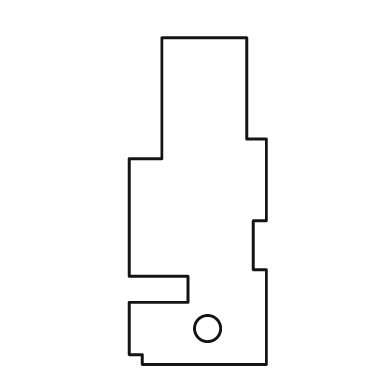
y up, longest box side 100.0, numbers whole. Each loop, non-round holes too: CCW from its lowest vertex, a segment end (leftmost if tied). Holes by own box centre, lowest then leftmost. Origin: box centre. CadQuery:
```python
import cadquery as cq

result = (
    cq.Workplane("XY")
    .moveTo(-17.0, -50.0)
    .lineTo(21.0, -50.0)
    .lineTo(21.0, -21.0)
    .lineTo(17.0, -21.0)
    .lineTo(17.0, -6.0)
    .lineTo(21.0, -6.0)
    .lineTo(21.0, 19.0)
    .lineTo(15.0, 19.0)
    .lineTo(15.0, 50.0)
    .lineTo(-11.0, 50.0)
    .lineTo(-11.0, 13.0)
    .lineTo(-21.0, 13.0)
    .lineTo(-21.0, -23.0)
    .lineTo(-3.0, -23.0)
    .lineTo(-3.0, -31.0)
    .lineTo(-21.0, -31.0)
    .lineTo(-21.0, -47.0)
    .lineTo(-17.0, -47.0)
    .close()
    .moveTo(3.0, -39.0)
    .circle(4.0)
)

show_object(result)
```